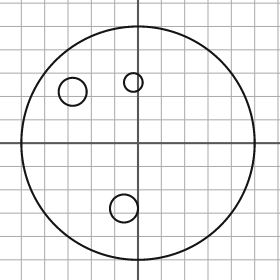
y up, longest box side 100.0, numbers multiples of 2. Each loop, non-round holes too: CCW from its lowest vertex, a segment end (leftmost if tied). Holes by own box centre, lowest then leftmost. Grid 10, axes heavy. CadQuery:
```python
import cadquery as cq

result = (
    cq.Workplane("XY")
    .moveTo(0.0, 0.0)
    .circle(50.0)
    .moveTo(-6.0, -28.0)
    .circle(6.0)
    .moveTo(-28.0, 22.0)
    .circle(6.0)
    .moveTo(-2.0, 26.0)
    .circle(4.0)
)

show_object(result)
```